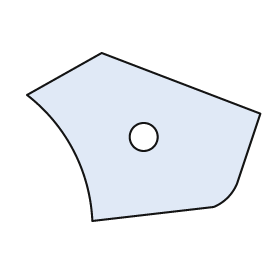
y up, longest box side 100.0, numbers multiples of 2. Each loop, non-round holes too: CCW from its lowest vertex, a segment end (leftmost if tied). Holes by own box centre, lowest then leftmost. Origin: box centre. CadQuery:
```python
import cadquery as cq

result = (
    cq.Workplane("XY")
    .moveTo(-22.0, -36.0)
    .lineTo(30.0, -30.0)
    .threePointArc((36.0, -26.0), (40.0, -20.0))
    .lineTo(50.0, 10.0)
    .lineTo(-18.0, 36.0)
    .lineTo(-50.0, 18.0)
    .threePointArc((-30.0, -6.0), (-22.0, -36.0))
    .close()
    .moveTo(0.0, 0.0)
    .circle(6.0)
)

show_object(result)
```